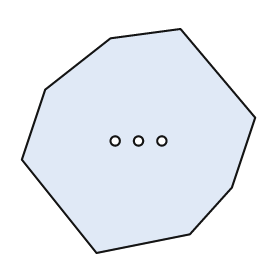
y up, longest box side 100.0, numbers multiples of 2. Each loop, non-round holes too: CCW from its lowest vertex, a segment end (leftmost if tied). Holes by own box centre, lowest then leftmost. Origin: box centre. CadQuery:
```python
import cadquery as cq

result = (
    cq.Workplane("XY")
    .moveTo(-18.0, -48.0)
    .lineTo(22.0, -40.0)
    .lineTo(40.0, -20.0)
    .lineTo(50.0, 10.0)
    .lineTo(18.0, 48.0)
    .lineTo(-12.0, 44.0)
    .lineTo(-40.0, 22.0)
    .lineTo(-50.0, -8.0)
    .close()
    .moveTo(-10.0, 0.0)
    .circle(2.0)
    .moveTo(0.0, 0.0)
    .circle(2.0)
    .moveTo(10.0, 0.0)
    .circle(2.0)
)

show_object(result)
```